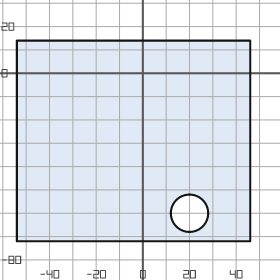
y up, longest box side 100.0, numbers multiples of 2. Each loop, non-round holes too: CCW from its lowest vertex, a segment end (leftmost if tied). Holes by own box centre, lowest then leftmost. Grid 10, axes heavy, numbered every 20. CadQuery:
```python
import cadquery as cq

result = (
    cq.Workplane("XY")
    .moveTo(-54.0, -72.0)
    .lineTo(46.0, -72.0)
    .lineTo(46.0, 14.0)
    .lineTo(-54.0, 14.0)
    .close()
    .moveTo(20.0, -60.0)
    .circle(8.0)
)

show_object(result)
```